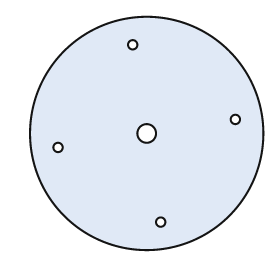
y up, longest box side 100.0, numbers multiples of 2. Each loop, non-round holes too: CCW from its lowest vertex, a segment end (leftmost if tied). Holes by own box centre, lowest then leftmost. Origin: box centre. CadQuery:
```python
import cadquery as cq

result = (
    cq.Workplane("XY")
    .moveTo(0.0, 0.0)
    .circle(50.0)
    .moveTo(6.0, -38.0)
    .circle(2.0)
    .moveTo(-38.0, -6.0)
    .circle(2.0)
    .moveTo(0.0, 0.0)
    .circle(4.0)
    .moveTo(38.0, 6.0)
    .circle(2.0)
    .moveTo(-6.0, 38.0)
    .circle(2.0)
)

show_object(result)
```